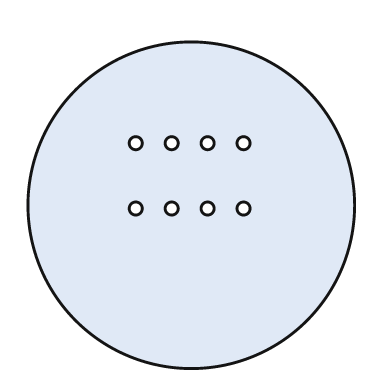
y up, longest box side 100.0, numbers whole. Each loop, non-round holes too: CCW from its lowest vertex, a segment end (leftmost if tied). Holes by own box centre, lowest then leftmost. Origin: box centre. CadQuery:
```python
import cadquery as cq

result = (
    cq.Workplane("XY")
    .moveTo(0.0, 0.0)
    .circle(50.0)
    .moveTo(-17.0, -1.0)
    .circle(2.0)
    .moveTo(-6.0, -1.0)
    .circle(2.0)
    .moveTo(5.0, -1.0)
    .circle(2.0)
    .moveTo(16.0, -1.0)
    .circle(2.0)
    .moveTo(-17.0, 19.0)
    .circle(2.0)
    .moveTo(-6.0, 19.0)
    .circle(2.0)
    .moveTo(5.0, 19.0)
    .circle(2.0)
    .moveTo(16.0, 19.0)
    .circle(2.0)
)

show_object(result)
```